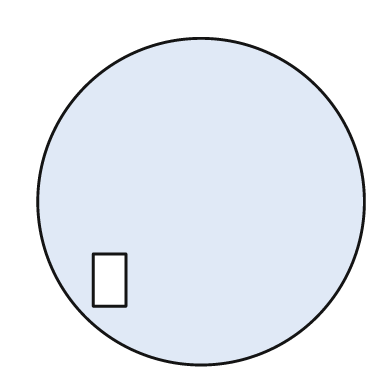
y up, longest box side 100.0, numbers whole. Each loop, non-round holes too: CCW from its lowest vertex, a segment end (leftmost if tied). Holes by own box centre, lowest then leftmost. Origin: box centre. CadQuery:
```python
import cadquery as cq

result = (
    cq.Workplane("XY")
    .moveTo(0.0, 0.0)
    .circle(50.0)
    .moveTo(-33.0, -32.0)
    .lineTo(-23.0, -32.0)
    .lineTo(-23.0, -16.0)
    .lineTo(-33.0, -16.0)
    .close()
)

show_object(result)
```